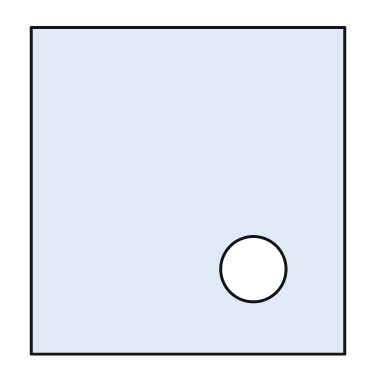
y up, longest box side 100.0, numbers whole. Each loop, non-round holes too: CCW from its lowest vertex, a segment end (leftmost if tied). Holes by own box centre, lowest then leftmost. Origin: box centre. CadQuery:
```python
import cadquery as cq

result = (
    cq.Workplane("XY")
    .moveTo(-48.0, -50.0)
    .lineTo(48.0, -50.0)
    .lineTo(48.0, 50.0)
    .lineTo(-48.0, 50.0)
    .close()
    .moveTo(20.0, -24.0)
    .circle(10.0)
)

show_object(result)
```